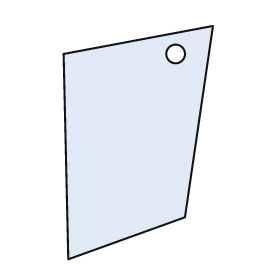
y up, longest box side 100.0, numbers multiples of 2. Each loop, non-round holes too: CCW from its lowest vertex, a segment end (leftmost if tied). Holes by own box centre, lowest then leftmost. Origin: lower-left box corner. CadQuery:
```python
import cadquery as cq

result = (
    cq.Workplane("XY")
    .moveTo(2.0, 0.0)
    .lineTo(52.0, 18.0)
    .lineTo(64.0, 100.0)
    .lineTo(0.0, 88.0)
    .close()
    .moveTo(48.0, 88.0)
    .circle(4.0)
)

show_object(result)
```